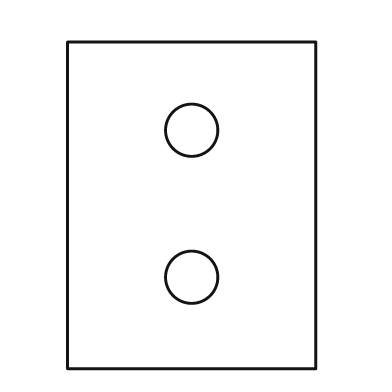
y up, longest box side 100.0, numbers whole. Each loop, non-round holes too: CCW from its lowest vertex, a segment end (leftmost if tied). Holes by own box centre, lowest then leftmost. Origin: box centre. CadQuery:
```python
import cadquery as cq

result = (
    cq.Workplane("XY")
    .moveTo(-38.0, -50.0)
    .lineTo(38.0, -50.0)
    .lineTo(38.0, 50.0)
    .lineTo(-38.0, 50.0)
    .close()
    .moveTo(0.0, -22.0)
    .circle(8.0)
    .moveTo(0.0, 23.0)
    .circle(8.0)
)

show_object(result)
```